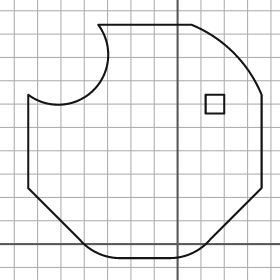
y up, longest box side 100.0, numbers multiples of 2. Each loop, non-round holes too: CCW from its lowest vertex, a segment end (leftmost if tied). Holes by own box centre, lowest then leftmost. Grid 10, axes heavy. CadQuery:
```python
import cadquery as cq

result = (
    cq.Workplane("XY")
    .moveTo(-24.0, -6.0)
    .lineTo(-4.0, -6.0)
    .threePointArc((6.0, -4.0), (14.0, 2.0))
    .lineTo(36.0, 24.0)
    .lineTo(36.0, 64.0)
    .threePointArc((24.0, 82.0), (6.0, 94.0))
    .lineTo(-34.0, 94.0)
    .threePointArc((-36.0, 66.0), (-64.0, 64.0))
    .lineTo(-64.0, 24.0)
    .lineTo(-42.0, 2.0)
    .threePointArc((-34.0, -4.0), (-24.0, -6.0))
    .close()
    .moveTo(12.0, 56.0)
    .lineTo(20.0, 56.0)
    .lineTo(20.0, 64.0)
    .lineTo(12.0, 64.0)
    .close()
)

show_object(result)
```